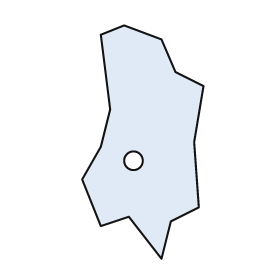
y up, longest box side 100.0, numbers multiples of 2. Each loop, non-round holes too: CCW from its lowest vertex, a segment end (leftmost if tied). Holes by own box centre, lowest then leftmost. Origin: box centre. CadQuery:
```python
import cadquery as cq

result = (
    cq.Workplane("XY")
    .moveTo(8.0, -50.0)
    .lineTo(12.0, -34.0)
    .lineTo(24.0, -28.0)
    .lineTo(22.0, 0.0)
    .lineTo(26.0, 24.0)
    .lineTo(14.0, 30.0)
    .lineTo(8.0, 44.0)
    .lineTo(-8.0, 50.0)
    .lineTo(-18.0, 46.0)
    .lineTo(-14.0, 14.0)
    .lineTo(-18.0, -2.0)
    .lineTo(-26.0, -16.0)
    .lineTo(-18.0, -36.0)
    .lineTo(-6.0, -32.0)
    .close()
    .moveTo(-4.0, -8.0)
    .circle(4.0)
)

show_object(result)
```